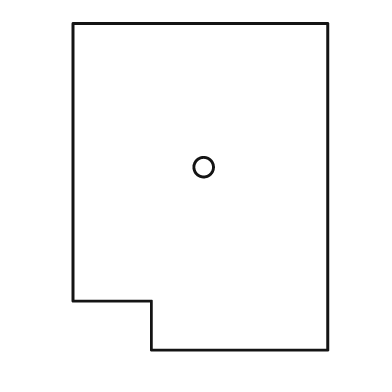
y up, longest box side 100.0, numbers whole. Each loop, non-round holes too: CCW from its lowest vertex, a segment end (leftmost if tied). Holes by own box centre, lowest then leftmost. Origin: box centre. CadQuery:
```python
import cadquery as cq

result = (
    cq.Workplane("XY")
    .moveTo(-15.0, -50.0)
    .lineTo(39.0, -50.0)
    .lineTo(39.0, 50.0)
    .lineTo(-39.0, 50.0)
    .lineTo(-39.0, -35.0)
    .lineTo(-15.0, -35.0)
    .close()
    .moveTo(1.0, 6.0)
    .circle(3.0)
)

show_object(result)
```